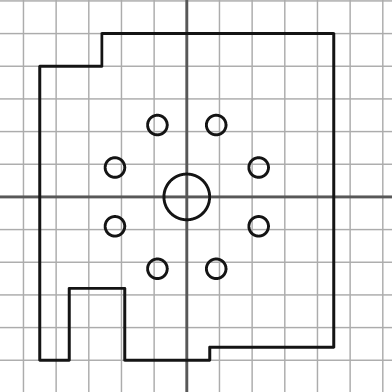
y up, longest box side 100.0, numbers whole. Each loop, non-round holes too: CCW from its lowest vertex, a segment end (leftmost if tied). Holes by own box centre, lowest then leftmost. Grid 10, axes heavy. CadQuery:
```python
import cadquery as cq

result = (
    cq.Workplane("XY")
    .moveTo(-45.0, -50.0)
    .lineTo(-36.0, -50.0)
    .lineTo(-36.0, -28.0)
    .lineTo(-19.0, -28.0)
    .lineTo(-19.0, -50.0)
    .lineTo(7.0, -50.0)
    .lineTo(7.0, -46.0)
    .lineTo(45.0, -46.0)
    .lineTo(45.0, 50.0)
    .lineTo(-26.0, 50.0)
    .lineTo(-26.0, 40.0)
    .lineTo(-45.0, 40.0)
    .close()
    .moveTo(-9.0, -22.0)
    .circle(3.0)
    .moveTo(9.0, -22.0)
    .circle(3.0)
    .moveTo(-22.0, -9.0)
    .circle(3.0)
    .moveTo(22.0, -9.0)
    .circle(3.0)
    .moveTo(0.0, 0.0)
    .circle(7.0)
    .moveTo(-22.0, 9.0)
    .circle(3.0)
    .moveTo(22.0, 9.0)
    .circle(3.0)
    .moveTo(-9.0, 22.0)
    .circle(3.0)
    .moveTo(9.0, 22.0)
    .circle(3.0)
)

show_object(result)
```